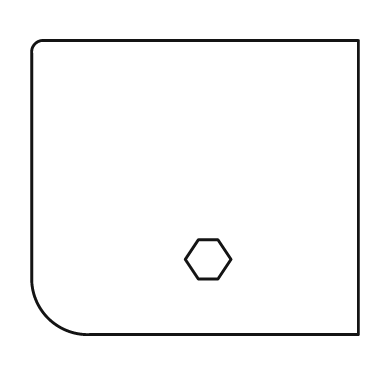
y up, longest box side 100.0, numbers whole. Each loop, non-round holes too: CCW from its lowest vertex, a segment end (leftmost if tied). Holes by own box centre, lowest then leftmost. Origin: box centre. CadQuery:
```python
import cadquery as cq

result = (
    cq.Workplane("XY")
    .moveTo(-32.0, -45.0)
    .lineTo(50.0, -45.0)
    .lineTo(50.0, 45.0)
    .lineTo(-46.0, 45.0)
    .threePointArc((-49.0, 44.0), (-50.0, 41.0))
    .lineTo(-50.0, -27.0)
    .threePointArc((-45.0, -40.0), (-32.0, -45.0))
    .close()
    .moveTo(1.0, -28.0)
    .lineTo(7.0, -28.0)
    .lineTo(11.0, -22.0)
    .lineTo(7.0, -16.0)
    .lineTo(1.0, -16.0)
    .lineTo(-3.0, -22.0)
    .close()
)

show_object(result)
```